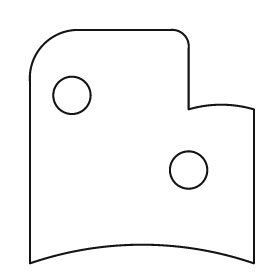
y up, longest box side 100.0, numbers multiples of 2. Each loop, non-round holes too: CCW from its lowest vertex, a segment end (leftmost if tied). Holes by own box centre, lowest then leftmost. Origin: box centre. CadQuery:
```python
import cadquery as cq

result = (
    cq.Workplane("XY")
    .moveTo(-48.0, -50.0)
    .threePointArc((0.0, -42.0), (48.0, -50.0))
    .lineTo(48.0, 16.0)
    .threePointArc((34.0, 18.0), (20.0, 16.0))
    .lineTo(20.0, 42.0)
    .threePointArc((18.0, 48.0), (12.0, 50.0))
    .lineTo(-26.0, 50.0)
    .threePointArc((-42.0, 44.0), (-48.0, 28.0))
    .close()
    .moveTo(20.0, -10.0)
    .circle(8.0)
    .moveTo(-30.0, 22.0)
    .circle(8.0)
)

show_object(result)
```